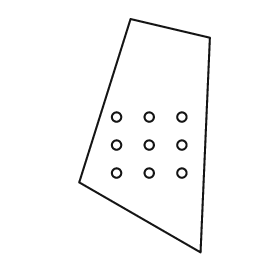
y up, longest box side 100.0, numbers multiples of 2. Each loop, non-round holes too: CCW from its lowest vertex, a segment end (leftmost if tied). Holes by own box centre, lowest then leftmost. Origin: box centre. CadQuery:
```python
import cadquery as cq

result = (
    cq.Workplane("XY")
    .moveTo(24.0, -50.0)
    .lineTo(28.0, 42.0)
    .lineTo(-6.0, 50.0)
    .lineTo(-28.0, -20.0)
    .close()
    .moveTo(-12.0, -16.0)
    .circle(2.0)
    .moveTo(2.0, -16.0)
    .circle(2.0)
    .moveTo(16.0, -16.0)
    .circle(2.0)
    .moveTo(-12.0, -4.0)
    .circle(2.0)
    .moveTo(2.0, -4.0)
    .circle(2.0)
    .moveTo(16.0, -4.0)
    .circle(2.0)
    .moveTo(-12.0, 8.0)
    .circle(2.0)
    .moveTo(2.0, 8.0)
    .circle(2.0)
    .moveTo(16.0, 8.0)
    .circle(2.0)
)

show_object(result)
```